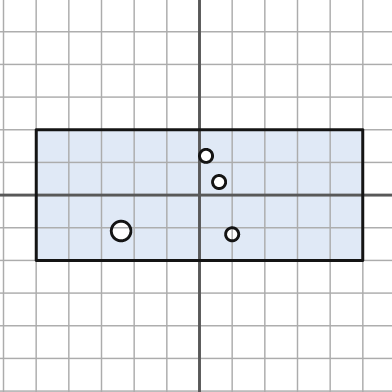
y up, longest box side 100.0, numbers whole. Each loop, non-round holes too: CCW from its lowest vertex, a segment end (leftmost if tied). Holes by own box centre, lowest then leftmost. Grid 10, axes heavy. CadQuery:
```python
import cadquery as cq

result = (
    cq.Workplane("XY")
    .moveTo(-50.0, -20.0)
    .lineTo(50.0, -20.0)
    .lineTo(50.0, 20.0)
    .lineTo(-50.0, 20.0)
    .close()
    .moveTo(10.0, -12.0)
    .circle(2.0)
    .moveTo(-24.0, -11.0)
    .circle(3.0)
    .moveTo(6.0, 4.0)
    .circle(2.0)
    .moveTo(2.0, 12.0)
    .circle(2.0)
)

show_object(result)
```